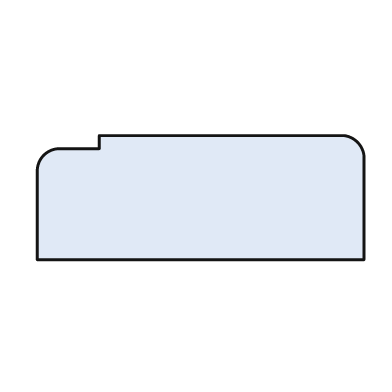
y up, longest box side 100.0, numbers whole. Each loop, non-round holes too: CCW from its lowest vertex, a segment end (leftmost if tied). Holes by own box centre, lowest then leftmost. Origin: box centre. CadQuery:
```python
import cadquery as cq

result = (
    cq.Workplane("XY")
    .moveTo(-50.0, -19.0)
    .lineTo(50.0, -19.0)
    .lineTo(50.0, 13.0)
    .threePointArc((48.0, 17.0), (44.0, 19.0))
    .lineTo(-31.0, 19.0)
    .lineTo(-31.0, 15.0)
    .lineTo(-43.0, 15.0)
    .threePointArc((-48.0, 13.0), (-50.0, 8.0))
    .close()
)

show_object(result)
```